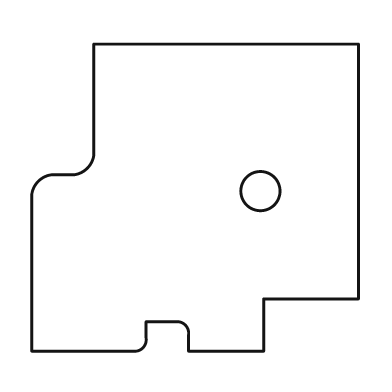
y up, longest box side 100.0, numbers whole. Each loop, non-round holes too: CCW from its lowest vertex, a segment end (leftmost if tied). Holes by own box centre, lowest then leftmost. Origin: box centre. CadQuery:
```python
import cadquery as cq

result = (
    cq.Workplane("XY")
    .moveTo(-50.0, -47.0)
    .lineTo(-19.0, -47.0)
    .threePointArc((-16.0, -46.0), (-15.0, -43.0))
    .lineTo(-15.0, -38.0)
    .lineTo(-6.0, -38.0)
    .threePointArc((-3.0, -39.0), (-2.0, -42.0))
    .lineTo(-2.0, -47.0)
    .lineTo(21.0, -47.0)
    .lineTo(21.0, -31.0)
    .lineTo(50.0, -31.0)
    .lineTo(50.0, 47.0)
    .lineTo(-31.0, 47.0)
    .lineTo(-31.0, 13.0)
    .threePointArc((-33.0, 9.0), (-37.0, 7.0))
    .lineTo(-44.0, 7.0)
    .threePointArc((-48.0, 5.0), (-50.0, 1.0))
    .close()
    .moveTo(20.0, 2.0)
    .circle(6.0)
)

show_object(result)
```